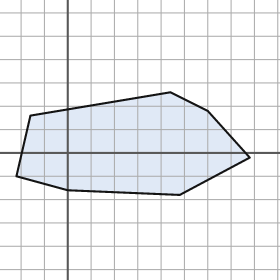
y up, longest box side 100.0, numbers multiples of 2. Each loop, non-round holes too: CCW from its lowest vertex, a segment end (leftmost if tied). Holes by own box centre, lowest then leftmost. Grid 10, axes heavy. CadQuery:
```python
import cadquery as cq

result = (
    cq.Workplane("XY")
    .moveTo(48.0, -18.0)
    .lineTo(78.0, -2.0)
    .lineTo(60.0, 18.0)
    .lineTo(44.0, 26.0)
    .lineTo(-16.0, 16.0)
    .lineTo(-22.0, -10.0)
    .lineTo(0.0, -16.0)
    .close()
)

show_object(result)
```